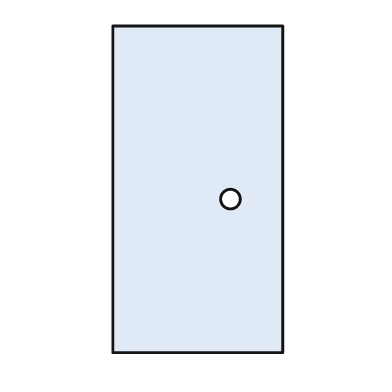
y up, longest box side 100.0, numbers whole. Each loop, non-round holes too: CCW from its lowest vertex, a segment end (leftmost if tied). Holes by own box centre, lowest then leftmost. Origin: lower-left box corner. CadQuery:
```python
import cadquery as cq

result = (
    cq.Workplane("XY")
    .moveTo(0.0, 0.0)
    .lineTo(52.0, 0.0)
    .lineTo(52.0, 100.0)
    .lineTo(0.0, 100.0)
    .close()
    .moveTo(36.0, 47.0)
    .circle(3.0)
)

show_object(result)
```